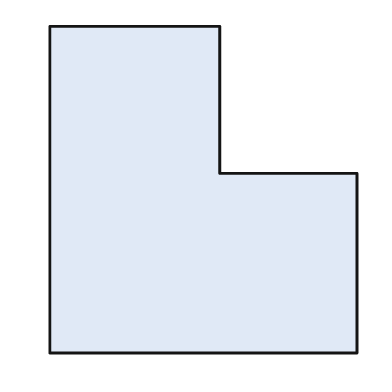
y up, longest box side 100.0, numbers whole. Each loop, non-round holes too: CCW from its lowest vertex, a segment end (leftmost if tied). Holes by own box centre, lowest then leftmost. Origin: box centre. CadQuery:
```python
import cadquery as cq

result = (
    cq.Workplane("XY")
    .moveTo(-47.0, -50.0)
    .lineTo(47.0, -50.0)
    .lineTo(47.0, 5.0)
    .lineTo(5.0, 5.0)
    .lineTo(5.0, 50.0)
    .lineTo(-47.0, 50.0)
    .close()
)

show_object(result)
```